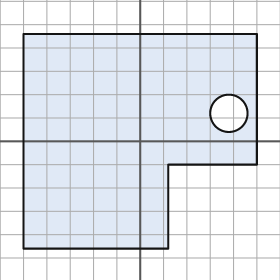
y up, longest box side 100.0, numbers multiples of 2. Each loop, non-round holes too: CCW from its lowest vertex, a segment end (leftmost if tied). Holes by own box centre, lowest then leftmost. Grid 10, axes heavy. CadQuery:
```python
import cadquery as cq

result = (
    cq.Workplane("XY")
    .moveTo(-50.0, -46.0)
    .lineTo(12.0, -46.0)
    .lineTo(12.0, -10.0)
    .lineTo(50.0, -10.0)
    .lineTo(50.0, 46.0)
    .lineTo(-50.0, 46.0)
    .close()
    .moveTo(38.0, 12.0)
    .circle(8.0)
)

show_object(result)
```